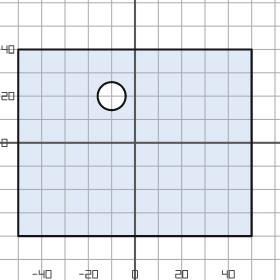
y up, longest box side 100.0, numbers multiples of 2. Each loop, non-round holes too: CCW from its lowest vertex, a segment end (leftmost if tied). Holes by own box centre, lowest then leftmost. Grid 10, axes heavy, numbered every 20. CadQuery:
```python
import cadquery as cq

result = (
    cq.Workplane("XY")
    .moveTo(-50.0, -40.0)
    .lineTo(50.0, -40.0)
    .lineTo(50.0, 40.0)
    .lineTo(-50.0, 40.0)
    .close()
    .moveTo(-10.0, 20.0)
    .circle(6.0)
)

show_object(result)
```